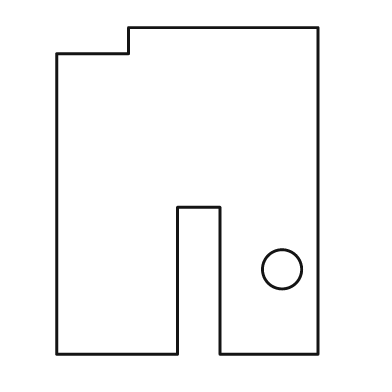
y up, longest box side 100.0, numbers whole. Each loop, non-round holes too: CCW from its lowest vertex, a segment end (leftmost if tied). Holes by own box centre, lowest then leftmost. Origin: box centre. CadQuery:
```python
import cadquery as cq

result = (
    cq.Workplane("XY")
    .moveTo(-40.0, -50.0)
    .lineTo(-3.0, -50.0)
    .lineTo(-3.0, -5.0)
    .lineTo(10.0, -5.0)
    .lineTo(10.0, -50.0)
    .lineTo(40.0, -50.0)
    .lineTo(40.0, 50.0)
    .lineTo(-18.0, 50.0)
    .lineTo(-18.0, 42.0)
    .lineTo(-40.0, 42.0)
    .close()
    .moveTo(29.0, -24.0)
    .circle(6.0)
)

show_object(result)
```